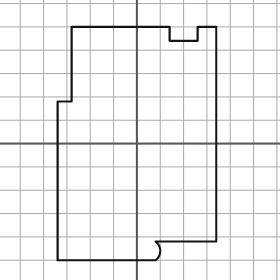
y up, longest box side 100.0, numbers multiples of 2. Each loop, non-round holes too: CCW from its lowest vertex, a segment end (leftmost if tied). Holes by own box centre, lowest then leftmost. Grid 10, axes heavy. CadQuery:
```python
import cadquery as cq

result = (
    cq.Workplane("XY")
    .moveTo(-34.0, -50.0)
    .lineTo(8.0, -50.0)
    .threePointArc((10.0, -46.0), (8.0, -42.0))
    .lineTo(34.0, -42.0)
    .lineTo(34.0, 50.0)
    .lineTo(26.0, 50.0)
    .lineTo(26.0, 44.0)
    .lineTo(14.0, 44.0)
    .lineTo(14.0, 50.0)
    .lineTo(-28.0, 50.0)
    .lineTo(-28.0, 18.0)
    .lineTo(-34.0, 18.0)
    .close()
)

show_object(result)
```